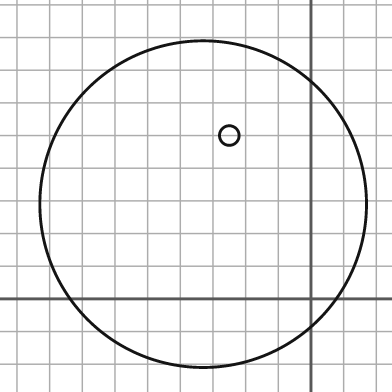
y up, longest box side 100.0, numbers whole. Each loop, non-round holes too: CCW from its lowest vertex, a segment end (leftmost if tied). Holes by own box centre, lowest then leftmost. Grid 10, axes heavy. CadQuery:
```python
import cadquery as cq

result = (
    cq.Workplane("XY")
    .moveTo(-33.0, 29.0)
    .circle(50.0)
    .moveTo(-25.0, 50.0)
    .circle(3.0)
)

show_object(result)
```